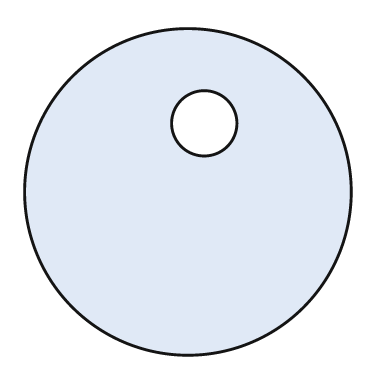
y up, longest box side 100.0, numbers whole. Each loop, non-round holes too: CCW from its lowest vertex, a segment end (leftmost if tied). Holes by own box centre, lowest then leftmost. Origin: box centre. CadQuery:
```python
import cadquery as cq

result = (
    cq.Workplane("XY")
    .moveTo(0.0, 0.0)
    .circle(50.0)
    .moveTo(5.0, 21.0)
    .circle(10.0)
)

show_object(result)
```